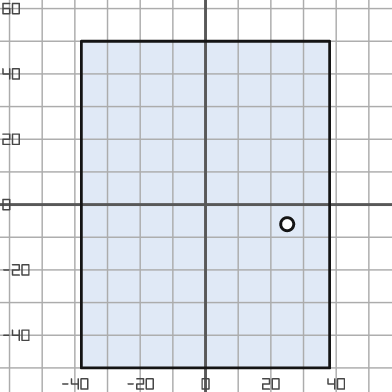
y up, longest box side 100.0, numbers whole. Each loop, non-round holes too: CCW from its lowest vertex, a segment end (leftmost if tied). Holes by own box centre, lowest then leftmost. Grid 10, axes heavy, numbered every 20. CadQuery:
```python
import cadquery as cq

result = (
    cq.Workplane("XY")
    .moveTo(-38.0, -50.0)
    .lineTo(38.0, -50.0)
    .lineTo(38.0, 50.0)
    .lineTo(-38.0, 50.0)
    .close()
    .moveTo(25.0, -6.0)
    .circle(2.0)
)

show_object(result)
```